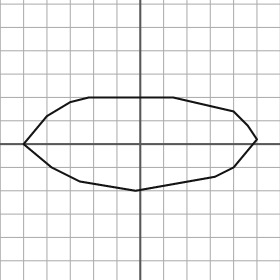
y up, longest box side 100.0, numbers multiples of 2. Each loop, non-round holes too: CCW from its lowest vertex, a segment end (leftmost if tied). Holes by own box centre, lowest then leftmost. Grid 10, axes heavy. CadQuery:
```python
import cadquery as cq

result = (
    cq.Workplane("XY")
    .moveTo(-2.0, -20.0)
    .lineTo(32.0, -14.0)
    .lineTo(40.0, -10.0)
    .lineTo(50.0, 2.0)
    .lineTo(46.0, 8.0)
    .lineTo(40.0, 14.0)
    .lineTo(14.0, 20.0)
    .lineTo(-22.0, 20.0)
    .lineTo(-30.0, 18.0)
    .lineTo(-40.0, 12.0)
    .lineTo(-50.0, 0.0)
    .lineTo(-38.0, -10.0)
    .lineTo(-26.0, -16.0)
    .close()
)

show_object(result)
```